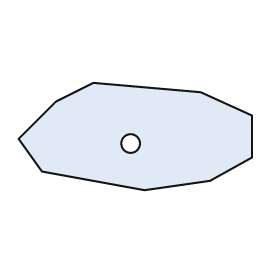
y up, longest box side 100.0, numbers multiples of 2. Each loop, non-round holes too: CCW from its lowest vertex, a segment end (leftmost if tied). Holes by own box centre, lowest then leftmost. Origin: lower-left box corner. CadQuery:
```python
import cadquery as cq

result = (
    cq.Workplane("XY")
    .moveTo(54.0, 0.0)
    .lineTo(82.0, 4.0)
    .lineTo(100.0, 14.0)
    .lineTo(100.0, 32.0)
    .lineTo(78.0, 42.0)
    .lineTo(32.0, 46.0)
    .lineTo(16.0, 38.0)
    .lineTo(0.0, 22.0)
    .lineTo(10.0, 8.0)
    .close()
    .moveTo(48.0, 20.0)
    .circle(4.0)
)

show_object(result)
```